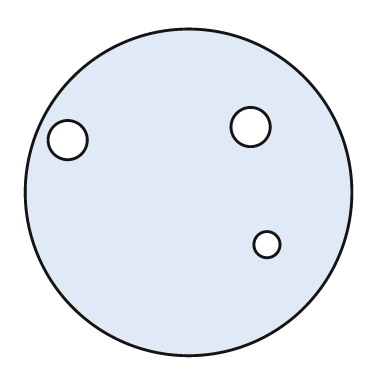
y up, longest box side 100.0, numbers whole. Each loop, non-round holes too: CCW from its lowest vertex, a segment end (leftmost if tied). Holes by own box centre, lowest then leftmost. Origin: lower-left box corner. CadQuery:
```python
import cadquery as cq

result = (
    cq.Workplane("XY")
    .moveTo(50.0, 50.0)
    .circle(50.0)
    .moveTo(74.0, 34.0)
    .circle(4.0)
    .moveTo(13.0, 66.0)
    .circle(6.0)
    .moveTo(69.0, 70.0)
    .circle(6.0)
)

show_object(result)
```